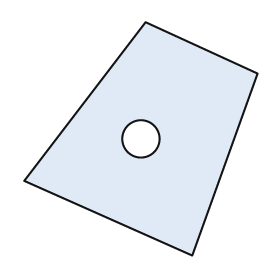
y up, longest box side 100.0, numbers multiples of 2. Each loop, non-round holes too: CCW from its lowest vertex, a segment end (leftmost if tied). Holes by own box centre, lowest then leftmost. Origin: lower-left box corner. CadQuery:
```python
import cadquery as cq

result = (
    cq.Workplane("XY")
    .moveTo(72.0, 0.0)
    .lineTo(100.0, 78.0)
    .lineTo(52.0, 100.0)
    .lineTo(0.0, 32.0)
    .close()
    .moveTo(50.0, 50.0)
    .circle(8.0)
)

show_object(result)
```